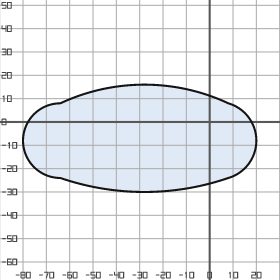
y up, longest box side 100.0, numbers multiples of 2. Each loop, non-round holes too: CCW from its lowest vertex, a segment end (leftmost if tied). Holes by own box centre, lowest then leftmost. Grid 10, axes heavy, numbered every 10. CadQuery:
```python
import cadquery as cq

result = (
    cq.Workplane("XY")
    .moveTo(-64.0, -24.0)
    .threePointArc((-28.0, -30.0), (8.0, -24.0))
    .threePointArc((20.0, -8.0), (8.0, 8.0))
    .threePointArc((-28.0, 16.0), (-64.0, 8.0))
    .threePointArc((-80.0, -8.0), (-64.0, -24.0))
    .close()
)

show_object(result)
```